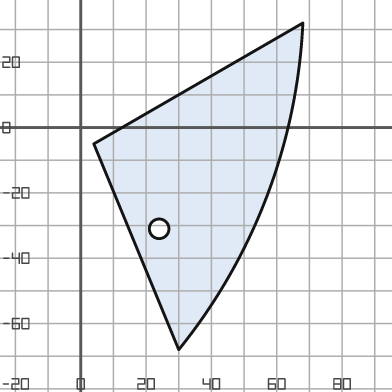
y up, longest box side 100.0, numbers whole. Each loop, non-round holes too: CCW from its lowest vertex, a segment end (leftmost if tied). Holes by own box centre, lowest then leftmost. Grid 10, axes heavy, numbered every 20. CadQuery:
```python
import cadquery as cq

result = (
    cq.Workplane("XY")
    .moveTo(30.0, -68.0)
    .threePointArc((57.0, -21.0), (68.0, 32.0))
    .lineTo(4.0, -5.0)
    .close()
    .moveTo(24.0, -31.0)
    .circle(3.0)
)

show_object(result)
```